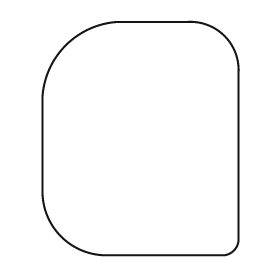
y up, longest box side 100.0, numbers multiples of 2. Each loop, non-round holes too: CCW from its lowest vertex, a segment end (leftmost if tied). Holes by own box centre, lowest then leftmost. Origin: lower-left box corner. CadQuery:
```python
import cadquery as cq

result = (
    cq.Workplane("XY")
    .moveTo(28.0, 0.0)
    .lineTo(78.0, 0.0)
    .threePointArc((82.0, 2.0), (84.0, 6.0))
    .lineTo(84.0, 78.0)
    .threePointArc((78.0, 94.0), (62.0, 100.0))
    .lineTo(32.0, 100.0)
    .threePointArc((10.0, 90.0), (0.0, 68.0))
    .lineTo(0.0, 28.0)
    .threePointArc((8.0, 8.0), (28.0, 0.0))
    .close()
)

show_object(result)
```